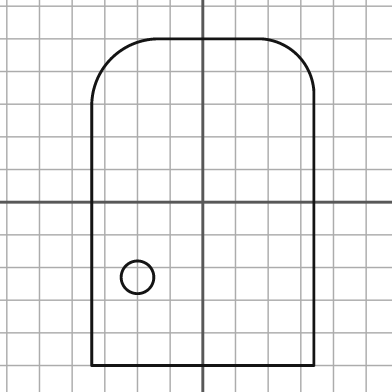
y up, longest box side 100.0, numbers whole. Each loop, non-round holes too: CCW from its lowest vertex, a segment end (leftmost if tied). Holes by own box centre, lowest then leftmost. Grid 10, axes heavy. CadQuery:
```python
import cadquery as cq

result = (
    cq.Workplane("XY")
    .moveTo(-34.0, -50.0)
    .lineTo(34.0, -50.0)
    .lineTo(34.0, 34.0)
    .threePointArc((29.0, 45.0), (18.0, 50.0))
    .lineTo(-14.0, 50.0)
    .threePointArc((-28.0, 44.0), (-34.0, 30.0))
    .close()
    .moveTo(-20.0, -23.0)
    .circle(5.0)
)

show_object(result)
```